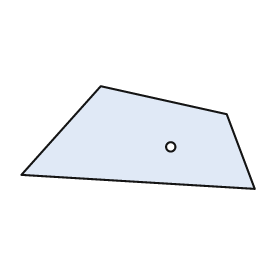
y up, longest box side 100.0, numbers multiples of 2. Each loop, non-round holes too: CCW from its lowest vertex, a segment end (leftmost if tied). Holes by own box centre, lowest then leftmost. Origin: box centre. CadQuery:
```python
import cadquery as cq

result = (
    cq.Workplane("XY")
    .moveTo(50.0, -22.0)
    .lineTo(38.0, 10.0)
    .lineTo(-16.0, 22.0)
    .lineTo(-50.0, -16.0)
    .close()
    .moveTo(14.0, -4.0)
    .circle(2.0)
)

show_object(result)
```